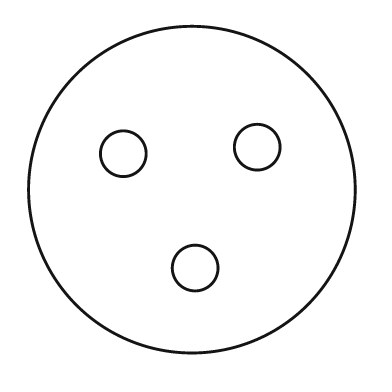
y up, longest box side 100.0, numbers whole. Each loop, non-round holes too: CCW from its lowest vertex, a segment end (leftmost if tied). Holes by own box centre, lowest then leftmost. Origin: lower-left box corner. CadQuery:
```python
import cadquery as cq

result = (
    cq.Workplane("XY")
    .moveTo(50.0, 50.0)
    .circle(50.0)
    .moveTo(51.0, 26.0)
    .circle(7.0)
    .moveTo(29.0, 61.0)
    .circle(7.0)
    .moveTo(70.0, 63.0)
    .circle(7.0)
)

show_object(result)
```